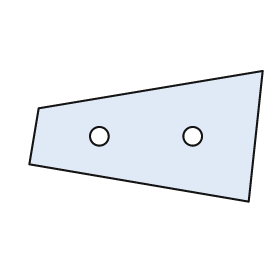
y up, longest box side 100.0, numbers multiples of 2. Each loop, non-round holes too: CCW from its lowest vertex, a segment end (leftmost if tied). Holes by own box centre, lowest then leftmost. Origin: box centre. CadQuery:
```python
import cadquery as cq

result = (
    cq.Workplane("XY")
    .moveTo(44.0, -28.0)
    .lineTo(50.0, 28.0)
    .lineTo(-46.0, 12.0)
    .lineTo(-50.0, -12.0)
    .close()
    .moveTo(-20.0, 0.0)
    .circle(4.0)
    .moveTo(20.0, 0.0)
    .circle(4.0)
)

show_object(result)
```